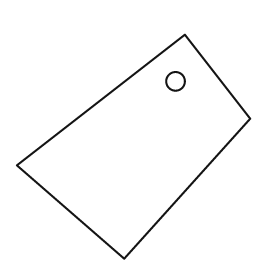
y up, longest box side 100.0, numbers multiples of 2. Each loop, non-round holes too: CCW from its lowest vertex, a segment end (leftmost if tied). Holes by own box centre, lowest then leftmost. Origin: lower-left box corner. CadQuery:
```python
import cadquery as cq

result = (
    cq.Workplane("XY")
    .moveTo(46.0, 0.0)
    .lineTo(100.0, 60.0)
    .lineTo(72.0, 96.0)
    .lineTo(0.0, 40.0)
    .close()
    .moveTo(68.0, 76.0)
    .circle(4.0)
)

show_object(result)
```